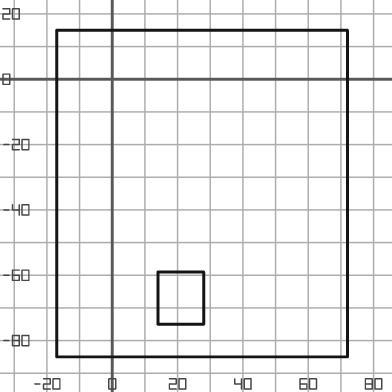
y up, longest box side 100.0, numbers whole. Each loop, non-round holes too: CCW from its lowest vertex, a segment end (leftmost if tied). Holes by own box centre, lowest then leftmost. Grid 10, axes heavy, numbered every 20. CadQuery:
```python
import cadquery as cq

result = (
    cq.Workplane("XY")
    .moveTo(-17.0, -85.0)
    .lineTo(72.0, -85.0)
    .lineTo(72.0, 15.0)
    .lineTo(-17.0, 15.0)
    .close()
    .moveTo(14.0, -75.0)
    .lineTo(28.0, -75.0)
    .lineTo(28.0, -59.0)
    .lineTo(14.0, -59.0)
    .close()
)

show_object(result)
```